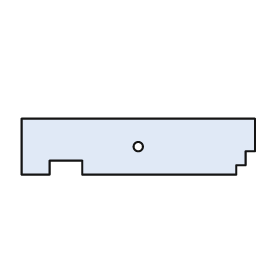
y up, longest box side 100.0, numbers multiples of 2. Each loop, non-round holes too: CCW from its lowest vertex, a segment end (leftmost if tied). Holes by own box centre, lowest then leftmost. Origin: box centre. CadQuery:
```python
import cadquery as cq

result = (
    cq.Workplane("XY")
    .moveTo(-50.0, -12.0)
    .lineTo(-38.0, -12.0)
    .lineTo(-38.0, -6.0)
    .lineTo(-24.0, -6.0)
    .lineTo(-24.0, -12.0)
    .lineTo(42.0, -12.0)
    .lineTo(42.0, -8.0)
    .lineTo(46.0, -8.0)
    .lineTo(46.0, -2.0)
    .lineTo(50.0, -2.0)
    .lineTo(50.0, 12.0)
    .lineTo(-50.0, 12.0)
    .close()
    .moveTo(0.0, 0.0)
    .circle(2.0)
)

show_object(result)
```